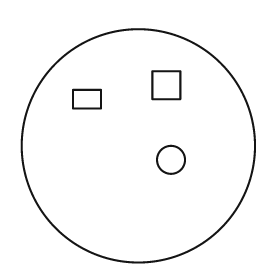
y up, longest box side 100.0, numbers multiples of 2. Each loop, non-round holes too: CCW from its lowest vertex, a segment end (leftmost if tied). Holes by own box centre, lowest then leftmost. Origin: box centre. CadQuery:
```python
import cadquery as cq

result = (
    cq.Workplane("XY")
    .moveTo(0.0, 0.0)
    .circle(50.0)
    .moveTo(14.0, -6.0)
    .circle(6.0)
    .moveTo(-28.0, 16.0)
    .lineTo(-16.0, 16.0)
    .lineTo(-16.0, 24.0)
    .lineTo(-28.0, 24.0)
    .close()
    .moveTo(6.0, 20.0)
    .lineTo(18.0, 20.0)
    .lineTo(18.0, 32.0)
    .lineTo(6.0, 32.0)
    .close()
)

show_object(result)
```